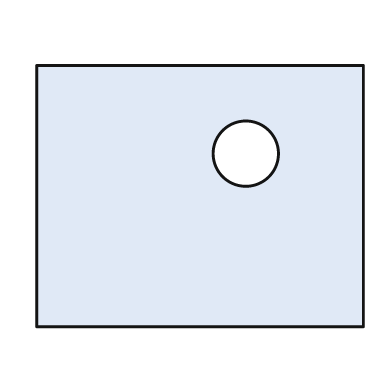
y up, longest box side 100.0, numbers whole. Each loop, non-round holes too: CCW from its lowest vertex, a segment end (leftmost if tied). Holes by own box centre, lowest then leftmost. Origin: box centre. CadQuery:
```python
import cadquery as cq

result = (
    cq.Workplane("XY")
    .moveTo(-50.0, -40.0)
    .lineTo(50.0, -40.0)
    .lineTo(50.0, 40.0)
    .lineTo(-50.0, 40.0)
    .close()
    .moveTo(14.0, 13.0)
    .circle(10.0)
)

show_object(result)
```